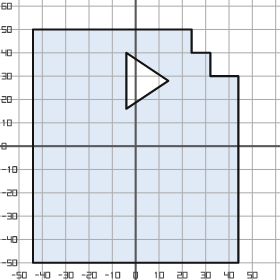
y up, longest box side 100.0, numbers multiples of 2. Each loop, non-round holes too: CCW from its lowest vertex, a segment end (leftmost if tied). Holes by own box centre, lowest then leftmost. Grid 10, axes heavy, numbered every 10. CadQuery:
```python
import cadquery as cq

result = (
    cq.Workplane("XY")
    .moveTo(-44.0, -50.0)
    .lineTo(44.0, -50.0)
    .lineTo(44.0, 30.0)
    .lineTo(32.0, 30.0)
    .lineTo(32.0, 40.0)
    .lineTo(24.0, 40.0)
    .lineTo(24.0, 50.0)
    .lineTo(-44.0, 50.0)
    .close()
    .moveTo(-4.0, 16.0)
    .lineTo(14.0, 28.0)
    .lineTo(-4.0, 40.0)
    .close()
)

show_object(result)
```